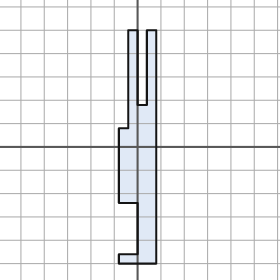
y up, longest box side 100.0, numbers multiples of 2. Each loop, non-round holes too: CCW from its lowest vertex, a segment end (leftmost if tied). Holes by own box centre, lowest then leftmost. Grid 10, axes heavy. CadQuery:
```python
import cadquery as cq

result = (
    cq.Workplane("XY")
    .moveTo(-8.0, -50.0)
    .lineTo(8.0, -50.0)
    .lineTo(8.0, 50.0)
    .lineTo(4.0, 50.0)
    .lineTo(4.0, 18.0)
    .lineTo(0.0, 18.0)
    .lineTo(0.0, 50.0)
    .lineTo(-4.0, 50.0)
    .lineTo(-4.0, 8.0)
    .lineTo(-8.0, 8.0)
    .lineTo(-8.0, -24.0)
    .lineTo(0.0, -24.0)
    .lineTo(0.0, -46.0)
    .lineTo(-8.0, -46.0)
    .close()
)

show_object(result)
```